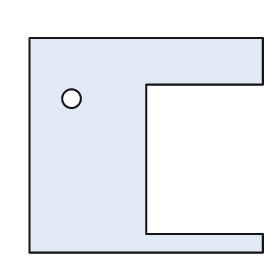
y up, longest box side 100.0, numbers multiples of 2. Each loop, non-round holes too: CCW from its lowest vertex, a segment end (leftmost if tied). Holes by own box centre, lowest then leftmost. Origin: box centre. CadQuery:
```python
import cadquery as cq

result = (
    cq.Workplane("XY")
    .moveTo(-50.0, -46.0)
    .lineTo(50.0, -46.0)
    .lineTo(50.0, -38.0)
    .lineTo(0.0, -38.0)
    .lineTo(0.0, 26.0)
    .lineTo(50.0, 26.0)
    .lineTo(50.0, 46.0)
    .lineTo(-50.0, 46.0)
    .close()
    .moveTo(-32.0, 20.0)
    .circle(4.0)
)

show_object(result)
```